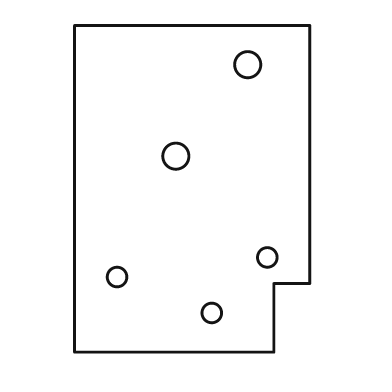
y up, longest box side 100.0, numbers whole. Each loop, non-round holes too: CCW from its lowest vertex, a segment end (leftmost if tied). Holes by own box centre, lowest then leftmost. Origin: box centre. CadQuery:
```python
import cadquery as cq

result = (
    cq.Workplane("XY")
    .moveTo(-36.0, -50.0)
    .lineTo(25.0, -50.0)
    .lineTo(25.0, -29.0)
    .lineTo(36.0, -29.0)
    .lineTo(36.0, 50.0)
    .lineTo(-36.0, 50.0)
    .close()
    .moveTo(6.0, -38.0)
    .circle(3.0)
    .moveTo(-23.0, -27.0)
    .circle(3.0)
    .moveTo(23.0, -21.0)
    .circle(3.0)
    .moveTo(-5.0, 10.0)
    .circle(4.0)
    .moveTo(17.0, 38.0)
    .circle(4.0)
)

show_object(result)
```